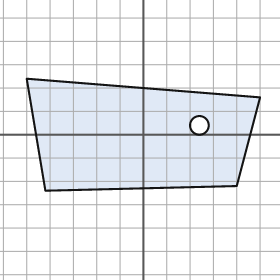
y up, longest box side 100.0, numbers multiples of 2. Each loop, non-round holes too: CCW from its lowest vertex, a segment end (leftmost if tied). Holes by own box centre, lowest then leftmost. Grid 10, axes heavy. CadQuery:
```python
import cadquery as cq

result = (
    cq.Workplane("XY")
    .moveTo(-42.0, -24.0)
    .lineTo(40.0, -22.0)
    .lineTo(50.0, 16.0)
    .lineTo(-50.0, 24.0)
    .close()
    .moveTo(24.0, 4.0)
    .circle(4.0)
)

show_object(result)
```